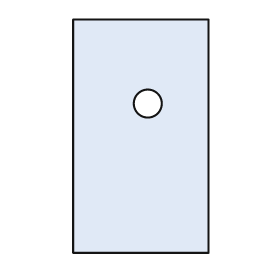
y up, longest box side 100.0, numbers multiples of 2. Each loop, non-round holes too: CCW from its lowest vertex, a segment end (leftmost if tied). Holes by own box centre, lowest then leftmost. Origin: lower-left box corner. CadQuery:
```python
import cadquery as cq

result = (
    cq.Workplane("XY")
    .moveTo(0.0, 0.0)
    .lineTo(58.0, 0.0)
    .lineTo(58.0, 100.0)
    .lineTo(0.0, 100.0)
    .close()
    .moveTo(32.0, 64.0)
    .circle(6.0)
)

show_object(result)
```